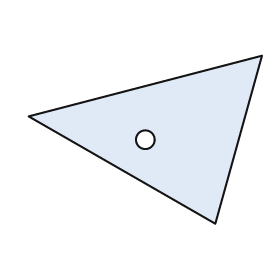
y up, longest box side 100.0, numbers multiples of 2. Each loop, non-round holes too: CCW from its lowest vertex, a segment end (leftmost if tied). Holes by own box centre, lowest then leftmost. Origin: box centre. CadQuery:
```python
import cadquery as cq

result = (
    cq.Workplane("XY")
    .moveTo(30.0, -36.0)
    .lineTo(50.0, 36.0)
    .lineTo(-50.0, 10.0)
    .close()
    .moveTo(0.0, 0.0)
    .circle(4.0)
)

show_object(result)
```